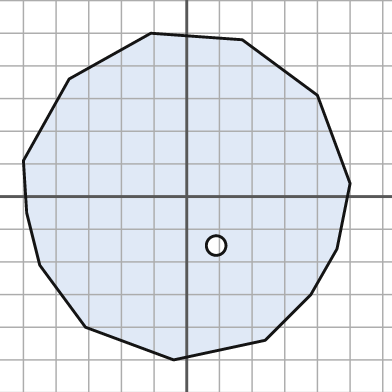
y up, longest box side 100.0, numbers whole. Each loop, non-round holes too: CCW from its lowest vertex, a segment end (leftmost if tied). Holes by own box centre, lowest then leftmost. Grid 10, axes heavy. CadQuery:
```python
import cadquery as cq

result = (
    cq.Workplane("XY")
    .moveTo(-4.0, -50.0)
    .lineTo(24.0, -44.0)
    .lineTo(38.0, -30.0)
    .lineTo(46.0, -16.0)
    .lineTo(50.0, 4.0)
    .lineTo(40.0, 31.0)
    .lineTo(17.0, 48.0)
    .lineTo(-11.0, 50.0)
    .lineTo(-36.0, 36.0)
    .lineTo(-50.0, 11.0)
    .lineTo(-49.0, -5.0)
    .lineTo(-45.0, -21.0)
    .lineTo(-31.0, -40.0)
    .close()
    .moveTo(9.0, -15.0)
    .circle(3.0)
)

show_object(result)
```